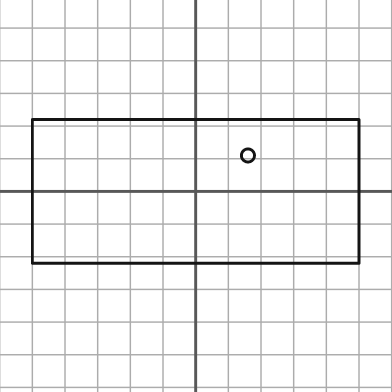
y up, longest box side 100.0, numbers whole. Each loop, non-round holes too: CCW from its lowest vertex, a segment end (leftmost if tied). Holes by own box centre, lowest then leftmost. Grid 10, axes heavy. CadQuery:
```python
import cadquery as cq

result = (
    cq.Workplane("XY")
    .moveTo(-50.0, -22.0)
    .lineTo(50.0, -22.0)
    .lineTo(50.0, 22.0)
    .lineTo(-50.0, 22.0)
    .close()
    .moveTo(16.0, 11.0)
    .circle(2.0)
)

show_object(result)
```